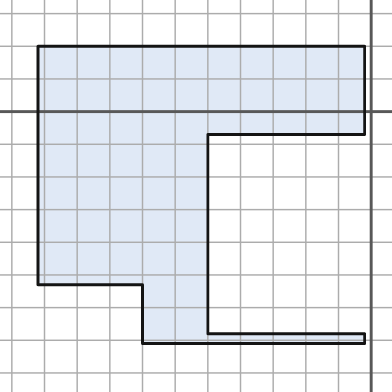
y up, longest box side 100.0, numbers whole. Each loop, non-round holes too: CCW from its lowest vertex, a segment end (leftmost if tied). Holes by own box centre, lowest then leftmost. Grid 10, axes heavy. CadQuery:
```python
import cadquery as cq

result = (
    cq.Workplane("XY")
    .moveTo(-70.0, -71.0)
    .lineTo(-2.0, -71.0)
    .lineTo(-2.0, -68.0)
    .lineTo(-50.0, -68.0)
    .lineTo(-50.0, -7.0)
    .lineTo(-2.0, -7.0)
    .lineTo(-2.0, 20.0)
    .lineTo(-102.0, 20.0)
    .lineTo(-102.0, -53.0)
    .lineTo(-70.0, -53.0)
    .close()
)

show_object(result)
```